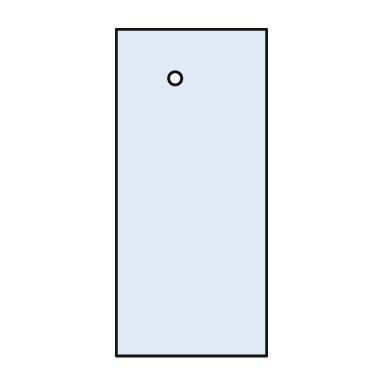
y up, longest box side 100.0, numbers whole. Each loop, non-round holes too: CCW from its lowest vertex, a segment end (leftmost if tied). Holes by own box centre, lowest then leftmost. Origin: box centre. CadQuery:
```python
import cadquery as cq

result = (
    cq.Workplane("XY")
    .moveTo(-23.0, -50.0)
    .lineTo(23.0, -50.0)
    .lineTo(23.0, 50.0)
    .lineTo(-23.0, 50.0)
    .close()
    .moveTo(-5.0, 35.0)
    .circle(2.0)
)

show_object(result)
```